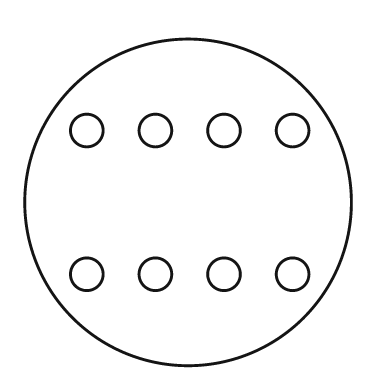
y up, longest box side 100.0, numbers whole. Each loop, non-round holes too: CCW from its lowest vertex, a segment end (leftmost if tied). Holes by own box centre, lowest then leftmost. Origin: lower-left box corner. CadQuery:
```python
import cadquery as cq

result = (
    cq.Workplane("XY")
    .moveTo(50.0, 50.0)
    .circle(50.0)
    .moveTo(19.0, 28.0)
    .circle(5.0)
    .moveTo(40.0, 28.0)
    .circle(5.0)
    .moveTo(61.0, 28.0)
    .circle(5.0)
    .moveTo(82.0, 28.0)
    .circle(5.0)
    .moveTo(19.0, 72.0)
    .circle(5.0)
    .moveTo(40.0, 72.0)
    .circle(5.0)
    .moveTo(61.0, 72.0)
    .circle(5.0)
    .moveTo(82.0, 72.0)
    .circle(5.0)
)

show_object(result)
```